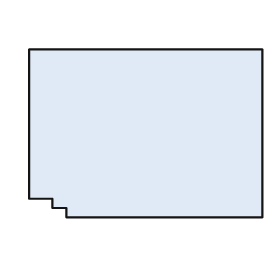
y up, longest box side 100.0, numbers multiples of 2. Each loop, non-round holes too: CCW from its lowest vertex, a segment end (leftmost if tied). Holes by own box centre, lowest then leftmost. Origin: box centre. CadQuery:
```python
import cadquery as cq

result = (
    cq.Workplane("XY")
    .moveTo(-34.0, -36.0)
    .lineTo(50.0, -36.0)
    .lineTo(50.0, 36.0)
    .lineTo(-50.0, 36.0)
    .lineTo(-50.0, -28.0)
    .lineTo(-40.0, -28.0)
    .lineTo(-40.0, -32.0)
    .lineTo(-34.0, -32.0)
    .close()
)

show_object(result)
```